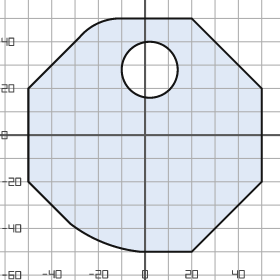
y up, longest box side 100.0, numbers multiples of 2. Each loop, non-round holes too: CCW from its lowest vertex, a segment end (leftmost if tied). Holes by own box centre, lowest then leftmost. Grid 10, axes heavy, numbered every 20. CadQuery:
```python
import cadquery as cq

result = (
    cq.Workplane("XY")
    .moveTo(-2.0, -50.0)
    .lineTo(20.0, -50.0)
    .lineTo(50.0, -20.0)
    .lineTo(50.0, 20.0)
    .lineTo(20.0, 50.0)
    .lineTo(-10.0, 50.0)
    .threePointArc((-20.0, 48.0), (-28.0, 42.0))
    .lineTo(-50.0, 20.0)
    .lineTo(-50.0, -20.0)
    .lineTo(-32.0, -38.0)
    .threePointArc((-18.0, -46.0), (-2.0, -50.0))
    .close()
    .moveTo(2.0, 28.0)
    .circle(12.0)
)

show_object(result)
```